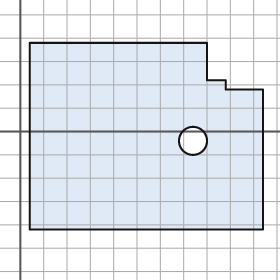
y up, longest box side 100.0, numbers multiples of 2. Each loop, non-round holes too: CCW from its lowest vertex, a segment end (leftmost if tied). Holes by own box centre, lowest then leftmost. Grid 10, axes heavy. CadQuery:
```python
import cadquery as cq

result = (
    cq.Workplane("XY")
    .moveTo(4.0, -42.0)
    .lineTo(104.0, -42.0)
    .lineTo(104.0, 18.0)
    .lineTo(88.0, 18.0)
    .lineTo(88.0, 22.0)
    .lineTo(80.0, 22.0)
    .lineTo(80.0, 38.0)
    .lineTo(4.0, 38.0)
    .close()
    .moveTo(74.0, -4.0)
    .circle(6.0)
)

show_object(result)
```